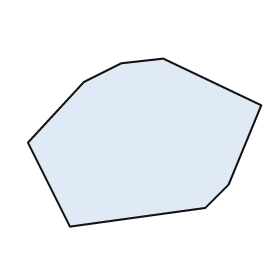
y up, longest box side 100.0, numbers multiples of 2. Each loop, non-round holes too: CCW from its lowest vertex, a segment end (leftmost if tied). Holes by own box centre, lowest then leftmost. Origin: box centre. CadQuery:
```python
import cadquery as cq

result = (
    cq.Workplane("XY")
    .moveTo(-32.0, -36.0)
    .lineTo(26.0, -28.0)
    .lineTo(36.0, -18.0)
    .lineTo(50.0, 16.0)
    .lineTo(8.0, 36.0)
    .lineTo(-10.0, 34.0)
    .lineTo(-26.0, 26.0)
    .lineTo(-50.0, 0.0)
    .close()
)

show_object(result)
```